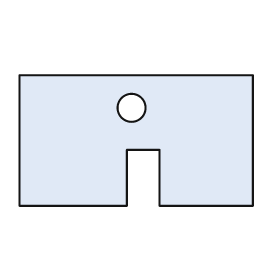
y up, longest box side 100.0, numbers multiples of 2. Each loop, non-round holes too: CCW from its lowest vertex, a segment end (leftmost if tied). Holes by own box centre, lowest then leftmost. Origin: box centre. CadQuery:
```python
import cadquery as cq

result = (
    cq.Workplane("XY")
    .moveTo(-50.0, -28.0)
    .lineTo(-4.0, -28.0)
    .lineTo(-4.0, -4.0)
    .lineTo(10.0, -4.0)
    .lineTo(10.0, -28.0)
    .lineTo(50.0, -28.0)
    .lineTo(50.0, 28.0)
    .lineTo(-50.0, 28.0)
    .close()
    .moveTo(-2.0, 14.0)
    .circle(6.0)
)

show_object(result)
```